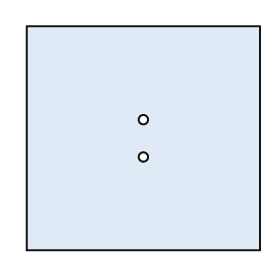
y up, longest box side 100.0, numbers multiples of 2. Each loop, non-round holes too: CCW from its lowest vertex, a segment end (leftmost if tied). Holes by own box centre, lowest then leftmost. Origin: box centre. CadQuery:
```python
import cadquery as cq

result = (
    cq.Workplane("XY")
    .moveTo(-50.0, -48.0)
    .lineTo(50.0, -48.0)
    .lineTo(50.0, 48.0)
    .lineTo(-50.0, 48.0)
    .close()
    .moveTo(0.0, -8.0)
    .circle(2.0)
    .moveTo(0.0, 8.0)
    .circle(2.0)
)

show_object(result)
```